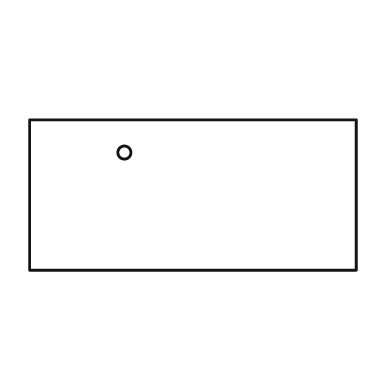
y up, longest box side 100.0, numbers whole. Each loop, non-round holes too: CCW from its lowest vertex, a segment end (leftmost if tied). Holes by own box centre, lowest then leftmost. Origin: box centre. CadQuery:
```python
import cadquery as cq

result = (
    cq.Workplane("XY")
    .moveTo(-50.0, -23.0)
    .lineTo(50.0, -23.0)
    .lineTo(50.0, 23.0)
    .lineTo(-50.0, 23.0)
    .close()
    .moveTo(-21.0, 13.0)
    .circle(2.0)
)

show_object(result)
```